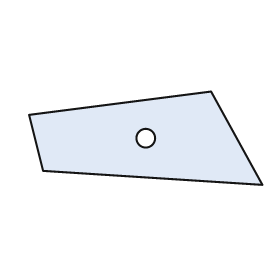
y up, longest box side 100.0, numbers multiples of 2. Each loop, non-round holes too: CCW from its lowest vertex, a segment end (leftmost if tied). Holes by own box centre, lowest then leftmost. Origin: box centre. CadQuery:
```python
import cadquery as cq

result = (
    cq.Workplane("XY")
    .moveTo(50.0, -20.0)
    .lineTo(28.0, 20.0)
    .lineTo(-50.0, 10.0)
    .lineTo(-44.0, -14.0)
    .close()
    .moveTo(0.0, 0.0)
    .circle(4.0)
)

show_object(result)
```